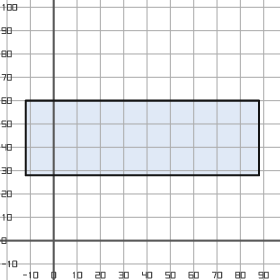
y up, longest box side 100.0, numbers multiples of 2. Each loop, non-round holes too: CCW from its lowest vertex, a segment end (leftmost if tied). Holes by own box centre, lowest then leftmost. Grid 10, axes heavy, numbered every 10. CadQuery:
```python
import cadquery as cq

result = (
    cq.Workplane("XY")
    .moveTo(-12.0, 28.0)
    .lineTo(88.0, 28.0)
    .lineTo(88.0, 60.0)
    .lineTo(-12.0, 60.0)
    .close()
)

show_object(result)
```